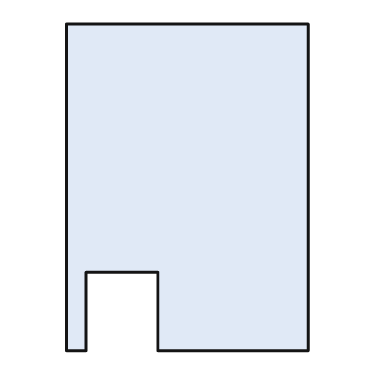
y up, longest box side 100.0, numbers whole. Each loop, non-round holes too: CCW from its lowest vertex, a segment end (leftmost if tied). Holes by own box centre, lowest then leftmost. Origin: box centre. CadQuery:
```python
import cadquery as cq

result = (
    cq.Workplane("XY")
    .moveTo(-37.0, -50.0)
    .lineTo(-31.0, -50.0)
    .lineTo(-31.0, -26.0)
    .lineTo(-9.0, -26.0)
    .lineTo(-9.0, -50.0)
    .lineTo(37.0, -50.0)
    .lineTo(37.0, 50.0)
    .lineTo(-37.0, 50.0)
    .close()
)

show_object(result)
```